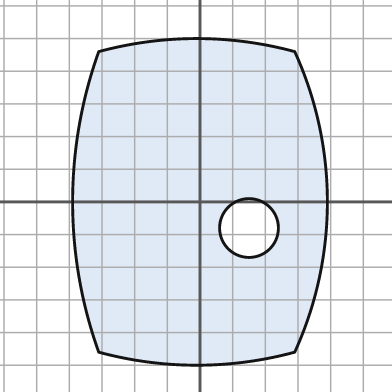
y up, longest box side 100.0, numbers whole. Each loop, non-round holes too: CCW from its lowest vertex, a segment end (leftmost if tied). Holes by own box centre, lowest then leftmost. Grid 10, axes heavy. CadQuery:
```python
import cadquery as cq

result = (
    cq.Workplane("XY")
    .moveTo(-31.0, -46.0)
    .threePointArc((-1.0, -50.0), (29.0, -46.0))
    .threePointArc((39.0, 0.0), (29.0, 46.0))
    .threePointArc((-1.0, 50.0), (-31.0, 46.0))
    .threePointArc((-39.0, 0.0), (-31.0, -46.0))
    .close()
    .moveTo(15.0, -8.0)
    .circle(9.0)
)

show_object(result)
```